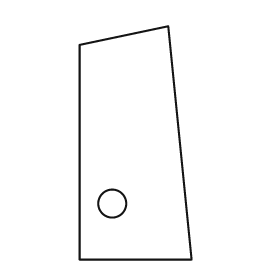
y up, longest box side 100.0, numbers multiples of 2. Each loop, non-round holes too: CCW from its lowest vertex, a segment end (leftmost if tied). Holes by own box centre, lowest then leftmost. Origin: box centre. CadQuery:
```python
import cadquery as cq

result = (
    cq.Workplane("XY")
    .moveTo(-24.0, -50.0)
    .lineTo(24.0, -50.0)
    .lineTo(14.0, 50.0)
    .lineTo(-24.0, 42.0)
    .close()
    .moveTo(-10.0, -26.0)
    .circle(6.0)
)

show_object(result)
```